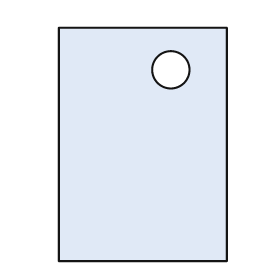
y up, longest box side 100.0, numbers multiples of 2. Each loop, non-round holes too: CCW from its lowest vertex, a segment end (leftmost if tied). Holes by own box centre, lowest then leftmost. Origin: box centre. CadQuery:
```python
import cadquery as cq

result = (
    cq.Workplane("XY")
    .moveTo(-36.0, -50.0)
    .lineTo(36.0, -50.0)
    .lineTo(36.0, 50.0)
    .lineTo(-36.0, 50.0)
    .close()
    .moveTo(12.0, 32.0)
    .circle(8.0)
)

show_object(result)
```